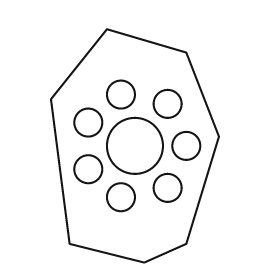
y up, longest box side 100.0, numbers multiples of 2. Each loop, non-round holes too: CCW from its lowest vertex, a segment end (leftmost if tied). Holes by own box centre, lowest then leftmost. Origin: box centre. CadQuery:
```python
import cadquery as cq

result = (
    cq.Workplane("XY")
    .moveTo(4.0, -50.0)
    .lineTo(22.0, -42.0)
    .lineTo(36.0, 4.0)
    .lineTo(22.0, 40.0)
    .lineTo(-12.0, 50.0)
    .lineTo(-36.0, 20.0)
    .lineTo(-28.0, -42.0)
    .close()
    .moveTo(-6.0, -22.0)
    .circle(6.0)
    .moveTo(14.0, -18.0)
    .circle(6.0)
    .moveTo(-20.0, -10.0)
    .circle(6.0)
    .moveTo(0.0, 0.0)
    .circle(12.0)
    .moveTo(22.0, 0.0)
    .circle(6.0)
    .moveTo(-20.0, 10.0)
    .circle(6.0)
    .moveTo(14.0, 18.0)
    .circle(6.0)
    .moveTo(-6.0, 22.0)
    .circle(6.0)
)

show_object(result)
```